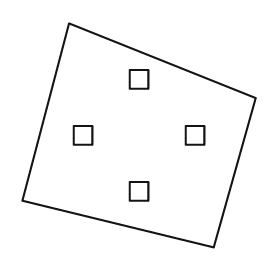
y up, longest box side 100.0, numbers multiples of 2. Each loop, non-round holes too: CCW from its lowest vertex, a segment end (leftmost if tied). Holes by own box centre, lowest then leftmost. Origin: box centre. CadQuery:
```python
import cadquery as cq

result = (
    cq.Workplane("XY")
    .moveTo(32.0, -48.0)
    .lineTo(50.0, 16.0)
    .lineTo(-30.0, 48.0)
    .lineTo(-50.0, -28.0)
    .close()
    .moveTo(-4.0, -28.0)
    .lineTo(4.0, -28.0)
    .lineTo(4.0, -20.0)
    .lineTo(-4.0, -20.0)
    .close()
    .moveTo(-28.0, -4.0)
    .lineTo(-20.0, -4.0)
    .lineTo(-20.0, 4.0)
    .lineTo(-28.0, 4.0)
    .close()
    .moveTo(20.0, -4.0)
    .lineTo(28.0, -4.0)
    .lineTo(28.0, 4.0)
    .lineTo(20.0, 4.0)
    .close()
    .moveTo(-4.0, 20.0)
    .lineTo(4.0, 20.0)
    .lineTo(4.0, 28.0)
    .lineTo(-4.0, 28.0)
    .close()
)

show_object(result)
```